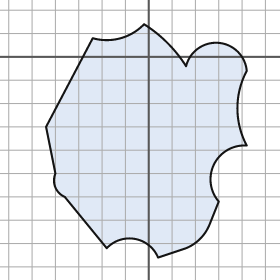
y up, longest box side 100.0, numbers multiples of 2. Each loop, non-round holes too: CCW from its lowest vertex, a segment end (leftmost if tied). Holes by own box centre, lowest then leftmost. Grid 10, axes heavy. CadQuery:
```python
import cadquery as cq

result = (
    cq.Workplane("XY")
    .moveTo(4.0, -86.0)
    .lineTo(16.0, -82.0)
    .threePointArc((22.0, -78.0), (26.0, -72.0))
    .lineTo(30.0, -62.0)
    .threePointArc((28.0, -46.0), (42.0, -38.0))
    .threePointArc((38.0, -22.0), (42.0, -6.0))
    .threePointArc((30.0, 6.0), (16.0, -4.0))
    .threePointArc((8.0, 6.0), (-2.0, 14.0))
    .threePointArc((-12.0, 8.0), (-24.0, 8.0))
    .lineTo(-44.0, -30.0)
    .lineTo(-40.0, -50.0)
    .threePointArc((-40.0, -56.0), (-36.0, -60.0))
    .lineTo(-18.0, -82.0)
    .threePointArc((-6.0, -78.0), (4.0, -86.0))
    .close()
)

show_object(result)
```